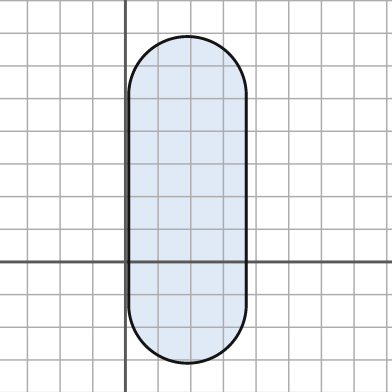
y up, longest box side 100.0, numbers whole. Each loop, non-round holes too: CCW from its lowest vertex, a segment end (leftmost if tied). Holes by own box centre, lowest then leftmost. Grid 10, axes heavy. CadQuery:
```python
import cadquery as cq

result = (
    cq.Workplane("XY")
    .moveTo(1.0, -13.0)
    .threePointArc((19.0, -31.0), (37.0, -13.0))
    .lineTo(37.0, 51.0)
    .threePointArc((19.0, 69.0), (1.0, 51.0))
    .close()
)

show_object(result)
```